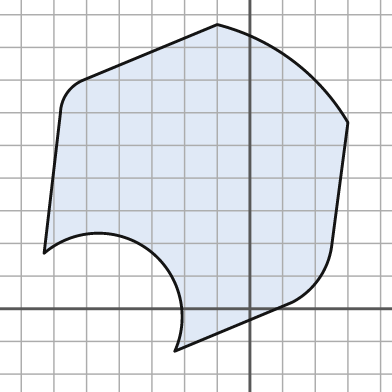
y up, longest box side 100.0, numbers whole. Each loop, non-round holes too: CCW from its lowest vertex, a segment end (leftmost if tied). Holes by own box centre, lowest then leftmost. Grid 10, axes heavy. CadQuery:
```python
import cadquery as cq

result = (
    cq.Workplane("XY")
    .moveTo(-23.0, -13.0)
    .lineTo(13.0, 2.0)
    .threePointArc((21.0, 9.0), (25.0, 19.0))
    .lineTo(30.0, 57.0)
    .threePointArc((13.0, 76.0), (-10.0, 87.0))
    .lineTo(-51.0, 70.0)
    .threePointArc((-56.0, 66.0), (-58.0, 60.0))
    .lineTo(-63.0, 17.0)
    .threePointArc((-31.0, 18.0), (-23.0, -13.0))
    .close()
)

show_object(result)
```